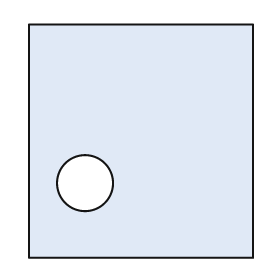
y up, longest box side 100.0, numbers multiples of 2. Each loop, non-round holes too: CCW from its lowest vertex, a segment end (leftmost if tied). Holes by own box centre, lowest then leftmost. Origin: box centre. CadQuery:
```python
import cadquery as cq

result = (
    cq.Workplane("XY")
    .moveTo(-48.0, -50.0)
    .lineTo(48.0, -50.0)
    .lineTo(48.0, 50.0)
    .lineTo(-48.0, 50.0)
    .close()
    .moveTo(-24.0, -18.0)
    .circle(12.0)
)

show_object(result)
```